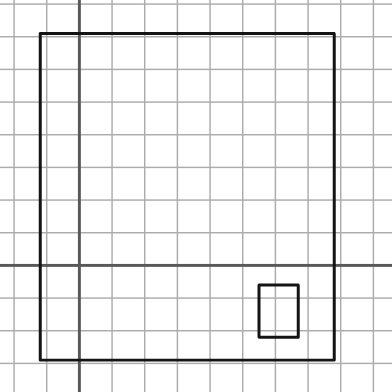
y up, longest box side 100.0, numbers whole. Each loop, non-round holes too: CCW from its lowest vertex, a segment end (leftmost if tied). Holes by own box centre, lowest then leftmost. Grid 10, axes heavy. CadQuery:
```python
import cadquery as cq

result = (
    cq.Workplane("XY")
    .moveTo(-12.0, -29.0)
    .lineTo(78.0, -29.0)
    .lineTo(78.0, 71.0)
    .lineTo(-12.0, 71.0)
    .close()
    .moveTo(55.0, -22.0)
    .lineTo(67.0, -22.0)
    .lineTo(67.0, -6.0)
    .lineTo(55.0, -6.0)
    .close()
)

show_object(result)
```